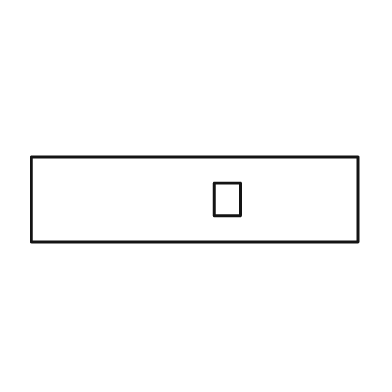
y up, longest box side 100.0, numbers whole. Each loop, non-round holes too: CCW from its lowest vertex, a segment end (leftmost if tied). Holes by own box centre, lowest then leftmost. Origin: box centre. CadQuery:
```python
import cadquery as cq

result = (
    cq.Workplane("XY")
    .moveTo(-50.0, -13.0)
    .lineTo(50.0, -13.0)
    .lineTo(50.0, 13.0)
    .lineTo(-50.0, 13.0)
    .close()
    .moveTo(6.0, -5.0)
    .lineTo(14.0, -5.0)
    .lineTo(14.0, 5.0)
    .lineTo(6.0, 5.0)
    .close()
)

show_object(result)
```